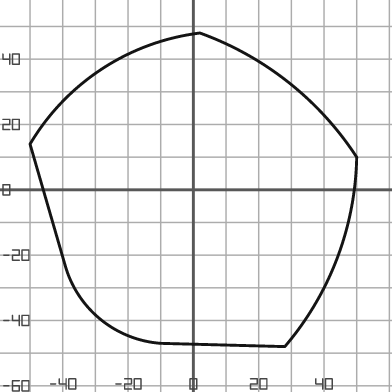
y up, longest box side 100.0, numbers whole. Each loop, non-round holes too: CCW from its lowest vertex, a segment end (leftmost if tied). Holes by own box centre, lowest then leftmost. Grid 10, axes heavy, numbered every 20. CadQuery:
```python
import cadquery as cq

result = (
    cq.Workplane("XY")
    .moveTo(28.0, -48.0)
    .threePointArc((44.0, -21.0), (50.0, 10.0))
    .threePointArc((29.0, 33.0), (2.0, 48.0))
    .threePointArc((-28.0, 37.0), (-50.0, 14.0))
    .lineTo(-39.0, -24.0)
    .threePointArc((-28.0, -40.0), (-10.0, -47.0))
    .close()
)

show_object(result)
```